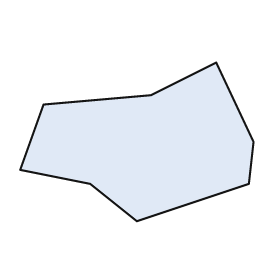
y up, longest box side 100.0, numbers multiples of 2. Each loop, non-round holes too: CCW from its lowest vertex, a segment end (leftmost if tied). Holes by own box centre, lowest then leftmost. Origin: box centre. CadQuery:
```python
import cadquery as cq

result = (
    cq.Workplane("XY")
    .moveTo(0.0, -34.0)
    .lineTo(48.0, -18.0)
    .lineTo(50.0, 0.0)
    .lineTo(34.0, 34.0)
    .lineTo(6.0, 20.0)
    .lineTo(-40.0, 16.0)
    .lineTo(-50.0, -12.0)
    .lineTo(-20.0, -18.0)
    .close()
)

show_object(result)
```